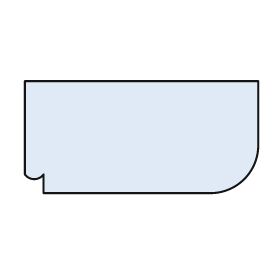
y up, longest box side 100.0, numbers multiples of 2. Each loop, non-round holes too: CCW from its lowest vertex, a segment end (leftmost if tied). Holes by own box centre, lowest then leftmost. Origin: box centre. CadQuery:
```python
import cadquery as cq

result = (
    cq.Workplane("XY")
    .moveTo(-42.0, -24.0)
    .lineTo(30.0, -24.0)
    .threePointArc((44.0, -18.0), (50.0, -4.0))
    .lineTo(50.0, 24.0)
    .lineTo(-50.0, 24.0)
    .lineTo(-50.0, -16.0)
    .threePointArc((-46.0, -18.0), (-42.0, -16.0))
    .close()
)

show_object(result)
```